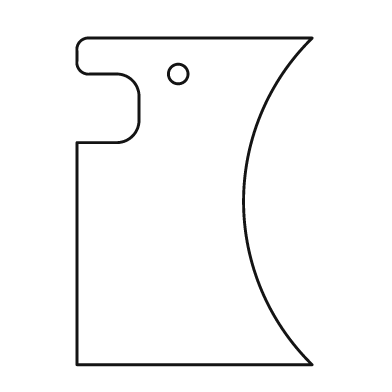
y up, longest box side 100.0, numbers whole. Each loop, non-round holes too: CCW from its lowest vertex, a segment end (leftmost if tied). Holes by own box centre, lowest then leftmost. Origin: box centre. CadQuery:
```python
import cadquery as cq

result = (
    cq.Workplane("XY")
    .moveTo(-36.0, -50.0)
    .lineTo(36.0, -50.0)
    .threePointArc((15.0, 0.0), (36.0, 50.0))
    .lineTo(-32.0, 50.0)
    .threePointArc((-35.0, 49.0), (-36.0, 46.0))
    .lineTo(-36.0, 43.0)
    .threePointArc((-35.0, 40.0), (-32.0, 39.0))
    .lineTo(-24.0, 39.0)
    .threePointArc((-19.0, 37.0), (-17.0, 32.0))
    .lineTo(-17.0, 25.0)
    .threePointArc((-19.0, 20.0), (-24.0, 18.0))
    .lineTo(-36.0, 18.0)
    .close()
    .moveTo(-5.0, 39.0)
    .circle(3.0)
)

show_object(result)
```